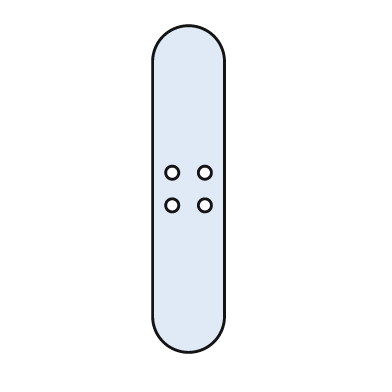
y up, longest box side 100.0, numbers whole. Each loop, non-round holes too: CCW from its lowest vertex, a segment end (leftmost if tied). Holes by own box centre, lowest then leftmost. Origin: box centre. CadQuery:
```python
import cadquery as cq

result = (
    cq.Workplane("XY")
    .moveTo(-11.0, -39.0)
    .threePointArc((0.0, -50.0), (11.0, -39.0))
    .lineTo(11.0, 39.0)
    .threePointArc((0.0, 50.0), (-11.0, 39.0))
    .close()
    .moveTo(-5.0, -5.0)
    .circle(2.0)
    .moveTo(5.0, -5.0)
    .circle(2.0)
    .moveTo(-5.0, 5.0)
    .circle(2.0)
    .moveTo(5.0, 5.0)
    .circle(2.0)
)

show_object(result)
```